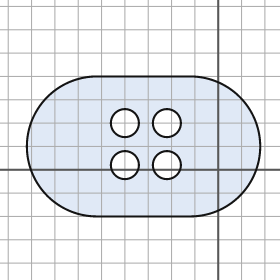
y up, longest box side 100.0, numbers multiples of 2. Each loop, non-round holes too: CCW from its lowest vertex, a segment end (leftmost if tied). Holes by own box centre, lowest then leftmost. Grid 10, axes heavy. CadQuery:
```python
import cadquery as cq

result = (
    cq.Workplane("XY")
    .moveTo(-52.0, -20.0)
    .lineTo(-12.0, -20.0)
    .threePointArc((18.0, 10.0), (-12.0, 40.0))
    .lineTo(-52.0, 40.0)
    .threePointArc((-82.0, 10.0), (-52.0, -20.0))
    .close()
    .moveTo(-40.0, 2.0)
    .circle(6.0)
    .moveTo(-22.0, 2.0)
    .circle(6.0)
    .moveTo(-40.0, 20.0)
    .circle(6.0)
    .moveTo(-22.0, 20.0)
    .circle(6.0)
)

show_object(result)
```